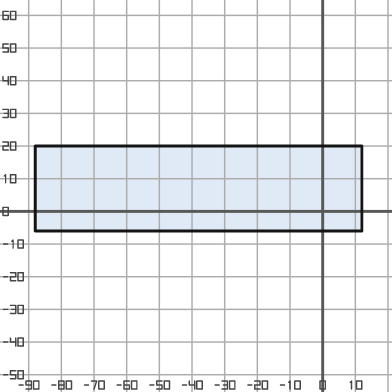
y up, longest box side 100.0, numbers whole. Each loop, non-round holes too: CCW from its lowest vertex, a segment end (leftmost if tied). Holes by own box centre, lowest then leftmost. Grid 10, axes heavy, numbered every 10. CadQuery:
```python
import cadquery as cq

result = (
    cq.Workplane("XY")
    .moveTo(-88.0, -6.0)
    .lineTo(12.0, -6.0)
    .lineTo(12.0, 20.0)
    .lineTo(-88.0, 20.0)
    .close()
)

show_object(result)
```